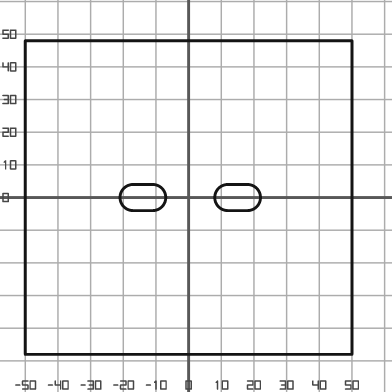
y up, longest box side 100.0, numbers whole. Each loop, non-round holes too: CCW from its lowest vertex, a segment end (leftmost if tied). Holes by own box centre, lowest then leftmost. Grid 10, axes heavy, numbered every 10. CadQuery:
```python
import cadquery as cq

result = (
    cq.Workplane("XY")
    .moveTo(-50.0, -48.0)
    .lineTo(50.0, -48.0)
    .lineTo(50.0, 48.0)
    .lineTo(-50.0, 48.0)
    .close()
    .moveTo(-17.0, -4.0)
    .lineTo(-11.0, -4.0)
    .threePointArc((-7.0, 0.0), (-11.0, 4.0))
    .lineTo(-17.0, 4.0)
    .threePointArc((-21.0, 0.0), (-17.0, -4.0))
    .close()
    .moveTo(12.0, -4.0)
    .lineTo(18.0, -4.0)
    .threePointArc((22.0, 0.0), (18.0, 4.0))
    .lineTo(12.0, 4.0)
    .threePointArc((8.0, 0.0), (12.0, -4.0))
    .close()
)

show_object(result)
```